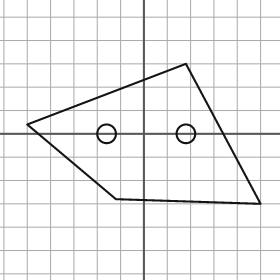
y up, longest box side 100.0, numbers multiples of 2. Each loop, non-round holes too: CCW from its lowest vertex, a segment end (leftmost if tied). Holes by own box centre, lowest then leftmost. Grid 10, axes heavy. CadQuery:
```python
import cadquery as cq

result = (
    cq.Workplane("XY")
    .moveTo(50.0, -30.0)
    .lineTo(18.0, 30.0)
    .lineTo(-50.0, 4.0)
    .lineTo(-12.0, -28.0)
    .close()
    .moveTo(-16.0, 0.0)
    .circle(4.0)
    .moveTo(18.0, 0.0)
    .circle(4.0)
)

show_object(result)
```